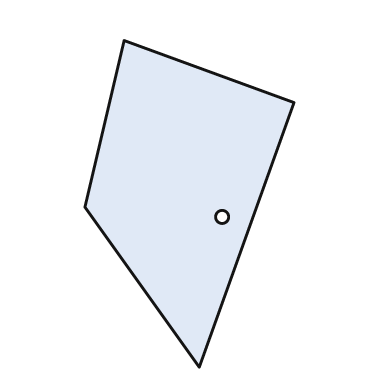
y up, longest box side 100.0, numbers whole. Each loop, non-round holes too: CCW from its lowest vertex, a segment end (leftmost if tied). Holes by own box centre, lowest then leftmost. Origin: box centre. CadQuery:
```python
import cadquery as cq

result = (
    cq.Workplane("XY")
    .moveTo(3.0, -50.0)
    .lineTo(32.0, 31.0)
    .lineTo(-20.0, 50.0)
    .lineTo(-32.0, -1.0)
    .close()
    .moveTo(10.0, -4.0)
    .circle(2.0)
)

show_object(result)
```